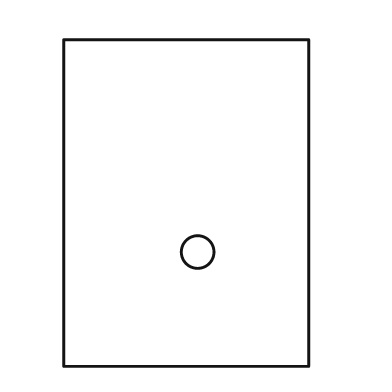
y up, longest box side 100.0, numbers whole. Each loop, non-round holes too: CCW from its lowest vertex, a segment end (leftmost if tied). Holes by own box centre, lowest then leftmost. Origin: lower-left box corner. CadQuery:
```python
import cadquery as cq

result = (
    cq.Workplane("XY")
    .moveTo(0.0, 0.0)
    .lineTo(75.0, 0.0)
    .lineTo(75.0, 100.0)
    .lineTo(0.0, 100.0)
    .close()
    .moveTo(41.0, 35.0)
    .circle(5.0)
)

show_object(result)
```